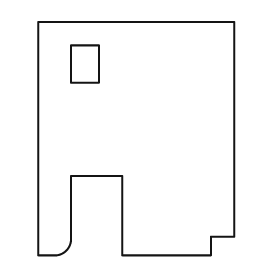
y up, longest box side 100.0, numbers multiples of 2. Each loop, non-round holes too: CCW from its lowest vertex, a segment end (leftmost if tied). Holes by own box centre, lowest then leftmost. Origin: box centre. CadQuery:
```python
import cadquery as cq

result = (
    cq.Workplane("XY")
    .moveTo(-42.0, -50.0)
    .lineTo(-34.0, -50.0)
    .threePointArc((-30.0, -48.0), (-28.0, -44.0))
    .lineTo(-28.0, -16.0)
    .lineTo(-6.0, -16.0)
    .lineTo(-6.0, -50.0)
    .lineTo(32.0, -50.0)
    .lineTo(32.0, -42.0)
    .lineTo(42.0, -42.0)
    .lineTo(42.0, 50.0)
    .lineTo(-42.0, 50.0)
    .close()
    .moveTo(-28.0, 24.0)
    .lineTo(-16.0, 24.0)
    .lineTo(-16.0, 40.0)
    .lineTo(-28.0, 40.0)
    .close()
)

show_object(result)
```